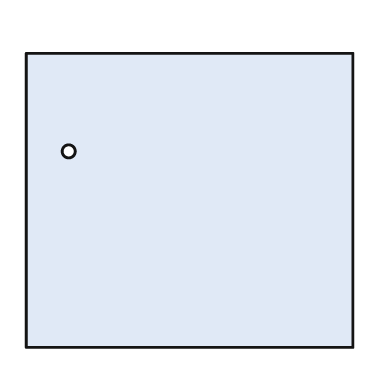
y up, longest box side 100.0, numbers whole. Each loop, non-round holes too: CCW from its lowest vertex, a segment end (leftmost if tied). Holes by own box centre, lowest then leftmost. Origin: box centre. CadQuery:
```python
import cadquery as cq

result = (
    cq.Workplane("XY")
    .moveTo(-50.0, -45.0)
    .lineTo(50.0, -45.0)
    .lineTo(50.0, 45.0)
    .lineTo(-50.0, 45.0)
    .close()
    .moveTo(-37.0, 15.0)
    .circle(2.0)
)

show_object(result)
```